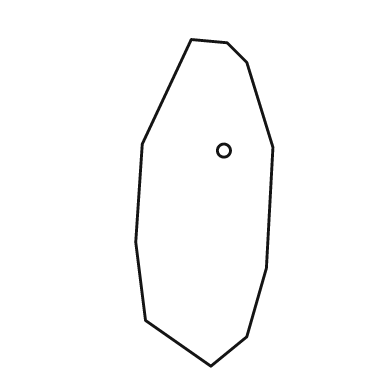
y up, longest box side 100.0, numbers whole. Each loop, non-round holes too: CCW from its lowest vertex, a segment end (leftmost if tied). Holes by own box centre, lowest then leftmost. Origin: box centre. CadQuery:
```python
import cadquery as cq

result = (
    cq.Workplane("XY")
    .moveTo(2.0, -50.0)
    .lineTo(13.0, -41.0)
    .lineTo(19.0, -20.0)
    .lineTo(21.0, 17.0)
    .lineTo(13.0, 43.0)
    .lineTo(7.0, 49.0)
    .lineTo(-4.0, 50.0)
    .lineTo(-19.0, 18.0)
    .lineTo(-21.0, -12.0)
    .lineTo(-18.0, -36.0)
    .close()
    .moveTo(6.0, 16.0)
    .circle(2.0)
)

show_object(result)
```